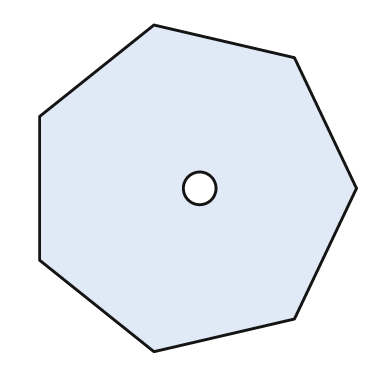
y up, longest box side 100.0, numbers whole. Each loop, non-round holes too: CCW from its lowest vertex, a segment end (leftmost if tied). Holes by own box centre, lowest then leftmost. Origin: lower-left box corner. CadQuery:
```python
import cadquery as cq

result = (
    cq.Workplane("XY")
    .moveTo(35.0, 0.0)
    .lineTo(78.0, 10.0)
    .lineTo(97.0, 50.0)
    .lineTo(78.0, 90.0)
    .lineTo(35.0, 100.0)
    .lineTo(0.0, 72.0)
    .lineTo(0.0, 28.0)
    .close()
    .moveTo(49.0, 50.0)
    .circle(5.0)
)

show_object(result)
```